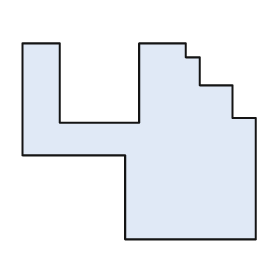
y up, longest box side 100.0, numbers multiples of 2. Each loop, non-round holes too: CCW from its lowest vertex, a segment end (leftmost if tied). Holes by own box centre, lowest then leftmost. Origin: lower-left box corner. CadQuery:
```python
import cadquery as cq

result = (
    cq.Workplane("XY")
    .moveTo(44.0, 0.0)
    .lineTo(100.0, 0.0)
    .lineTo(100.0, 52.0)
    .lineTo(90.0, 52.0)
    .lineTo(90.0, 66.0)
    .lineTo(76.0, 66.0)
    .lineTo(76.0, 78.0)
    .lineTo(70.0, 78.0)
    .lineTo(70.0, 84.0)
    .lineTo(50.0, 84.0)
    .lineTo(50.0, 50.0)
    .lineTo(16.0, 50.0)
    .lineTo(16.0, 84.0)
    .lineTo(0.0, 84.0)
    .lineTo(0.0, 36.0)
    .lineTo(44.0, 36.0)
    .close()
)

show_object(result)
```